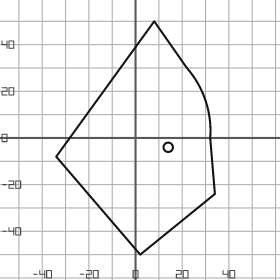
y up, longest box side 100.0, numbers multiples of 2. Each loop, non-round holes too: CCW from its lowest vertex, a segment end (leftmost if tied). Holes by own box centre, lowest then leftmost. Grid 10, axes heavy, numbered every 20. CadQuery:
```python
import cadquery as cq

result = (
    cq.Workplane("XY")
    .moveTo(2.0, -50.0)
    .lineTo(34.0, -24.0)
    .lineTo(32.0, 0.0)
    .threePointArc((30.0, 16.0), (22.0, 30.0))
    .lineTo(8.0, 50.0)
    .lineTo(-34.0, -8.0)
    .close()
    .moveTo(14.0, -4.0)
    .circle(2.0)
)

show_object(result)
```